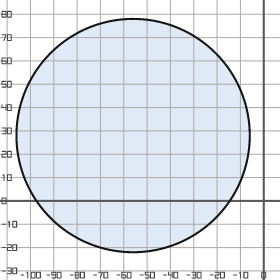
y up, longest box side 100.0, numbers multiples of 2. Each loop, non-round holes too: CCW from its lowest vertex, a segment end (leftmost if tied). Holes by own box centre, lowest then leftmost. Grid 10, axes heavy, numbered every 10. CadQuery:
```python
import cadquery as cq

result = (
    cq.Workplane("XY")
    .moveTo(-56.0, 28.0)
    .circle(50.0)
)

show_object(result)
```